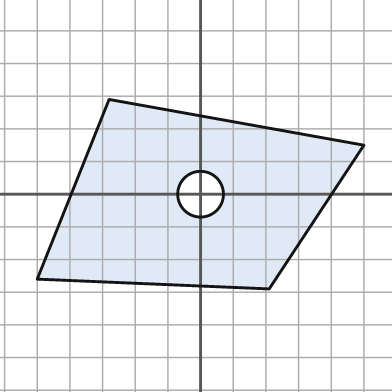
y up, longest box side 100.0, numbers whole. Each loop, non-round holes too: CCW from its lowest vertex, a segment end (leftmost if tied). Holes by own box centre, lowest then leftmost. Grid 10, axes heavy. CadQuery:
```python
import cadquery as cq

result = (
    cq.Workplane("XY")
    .moveTo(21.0, -29.0)
    .lineTo(50.0, 15.0)
    .lineTo(-28.0, 29.0)
    .lineTo(-50.0, -26.0)
    .close()
    .moveTo(0.0, 0.0)
    .circle(7.0)
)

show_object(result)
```